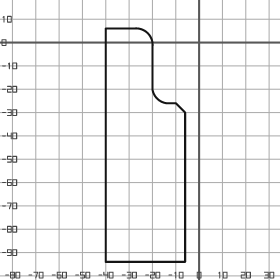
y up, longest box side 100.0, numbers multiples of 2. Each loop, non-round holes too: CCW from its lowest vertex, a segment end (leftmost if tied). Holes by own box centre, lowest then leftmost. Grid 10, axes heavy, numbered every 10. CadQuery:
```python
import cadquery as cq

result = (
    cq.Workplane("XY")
    .moveTo(-40.0, -94.0)
    .lineTo(-6.0, -94.0)
    .lineTo(-6.0, -30.0)
    .lineTo(-10.0, -26.0)
    .lineTo(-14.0, -26.0)
    .threePointArc((-18.0, -24.0), (-20.0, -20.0))
    .lineTo(-20.0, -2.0)
    .threePointArc((-22.0, 4.0), (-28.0, 6.0))
    .lineTo(-40.0, 6.0)
    .close()
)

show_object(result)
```